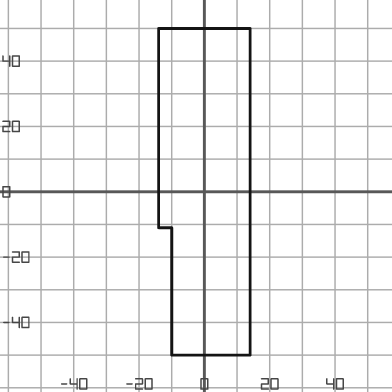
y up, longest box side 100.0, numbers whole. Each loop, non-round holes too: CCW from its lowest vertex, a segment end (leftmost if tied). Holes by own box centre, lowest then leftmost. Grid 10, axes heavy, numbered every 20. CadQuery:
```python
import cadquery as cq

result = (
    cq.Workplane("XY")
    .moveTo(-10.0, -50.0)
    .lineTo(14.0, -50.0)
    .lineTo(14.0, 50.0)
    .lineTo(-14.0, 50.0)
    .lineTo(-14.0, -11.0)
    .lineTo(-10.0, -11.0)
    .close()
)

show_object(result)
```